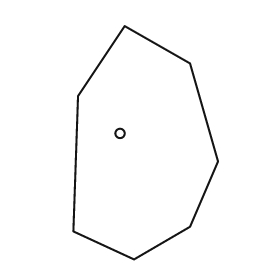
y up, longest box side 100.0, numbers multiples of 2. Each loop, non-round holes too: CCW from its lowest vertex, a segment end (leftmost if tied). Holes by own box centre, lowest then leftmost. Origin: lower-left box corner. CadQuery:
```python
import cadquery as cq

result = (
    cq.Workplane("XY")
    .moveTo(26.0, 0.0)
    .lineTo(50.0, 14.0)
    .lineTo(62.0, 42.0)
    .lineTo(50.0, 84.0)
    .lineTo(22.0, 100.0)
    .lineTo(2.0, 70.0)
    .lineTo(0.0, 12.0)
    .close()
    .moveTo(20.0, 54.0)
    .circle(2.0)
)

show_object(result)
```